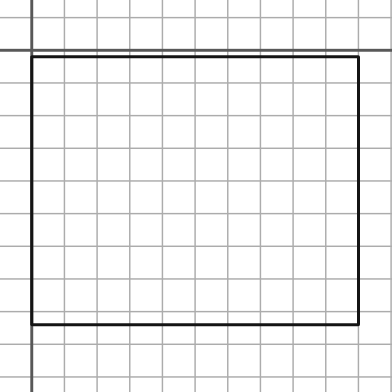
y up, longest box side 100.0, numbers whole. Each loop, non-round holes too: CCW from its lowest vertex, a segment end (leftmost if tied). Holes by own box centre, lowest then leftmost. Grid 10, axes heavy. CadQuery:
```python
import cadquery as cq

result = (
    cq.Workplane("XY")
    .moveTo(0.0, -84.0)
    .lineTo(100.0, -84.0)
    .lineTo(100.0, -2.0)
    .lineTo(0.0, -2.0)
    .close()
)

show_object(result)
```